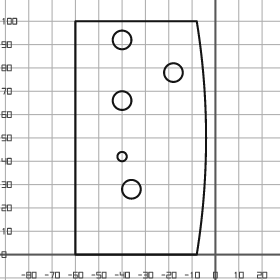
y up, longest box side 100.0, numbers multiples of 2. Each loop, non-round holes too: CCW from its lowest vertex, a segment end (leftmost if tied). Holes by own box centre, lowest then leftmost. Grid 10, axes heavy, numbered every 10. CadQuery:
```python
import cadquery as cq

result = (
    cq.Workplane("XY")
    .moveTo(-60.0, 0.0)
    .lineTo(-8.0, 0.0)
    .threePointArc((-4.0, 50.0), (-8.0, 100.0))
    .lineTo(-60.0, 100.0)
    .close()
    .moveTo(-36.0, 28.0)
    .circle(4.0)
    .moveTo(-40.0, 42.0)
    .circle(2.0)
    .moveTo(-40.0, 66.0)
    .circle(4.0)
    .moveTo(-18.0, 78.0)
    .circle(4.0)
    .moveTo(-40.0, 92.0)
    .circle(4.0)
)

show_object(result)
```